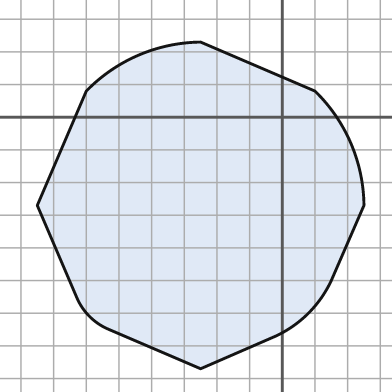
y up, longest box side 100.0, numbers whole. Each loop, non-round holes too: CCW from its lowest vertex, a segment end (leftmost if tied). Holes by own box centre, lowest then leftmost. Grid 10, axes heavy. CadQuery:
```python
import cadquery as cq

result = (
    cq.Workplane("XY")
    .moveTo(-25.0, -77.0)
    .lineTo(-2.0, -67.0)
    .threePointArc((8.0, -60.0), (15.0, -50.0))
    .lineTo(25.0, -27.0)
    .threePointArc((21.0, -8.0), (10.0, 8.0))
    .lineTo(-25.0, 23.0)
    .threePointArc((-44.0, 19.0), (-60.0, 8.0))
    .lineTo(-75.0, -27.0)
    .lineTo(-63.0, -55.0)
    .threePointArc((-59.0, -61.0), (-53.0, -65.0))
    .close()
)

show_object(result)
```